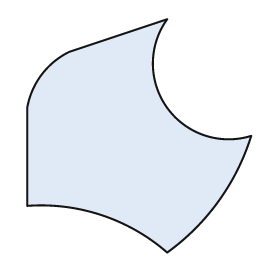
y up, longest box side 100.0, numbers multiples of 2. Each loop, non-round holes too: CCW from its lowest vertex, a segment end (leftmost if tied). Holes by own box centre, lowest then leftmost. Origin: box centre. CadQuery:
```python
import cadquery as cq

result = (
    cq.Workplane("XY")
    .moveTo(12.0, -50.0)
    .threePointArc((34.0, -28.0), (48.0, 0.0))
    .threePointArc((12.0, 12.0), (12.0, 50.0))
    .lineTo(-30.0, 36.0)
    .threePointArc((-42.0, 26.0), (-48.0, 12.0))
    .lineTo(-48.0, -30.0)
    .threePointArc((-16.0, -34.0), (12.0, -50.0))
    .close()
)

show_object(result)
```